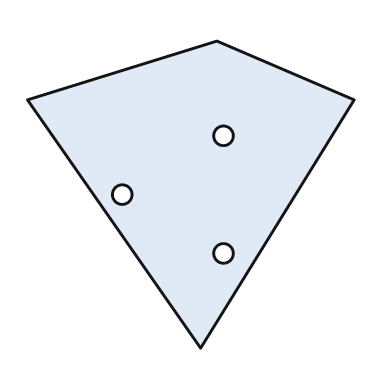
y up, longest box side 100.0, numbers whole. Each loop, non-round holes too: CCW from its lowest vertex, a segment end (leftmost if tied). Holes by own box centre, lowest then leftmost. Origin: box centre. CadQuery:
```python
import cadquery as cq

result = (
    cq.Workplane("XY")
    .moveTo(3.0, -47.0)
    .lineTo(50.0, 29.0)
    .lineTo(8.0, 47.0)
    .lineTo(-50.0, 29.0)
    .close()
    .moveTo(10.0, -18.0)
    .circle(3.0)
    .moveTo(-21.0, 0.0)
    .circle(3.0)
    .moveTo(10.0, 18.0)
    .circle(3.0)
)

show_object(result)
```